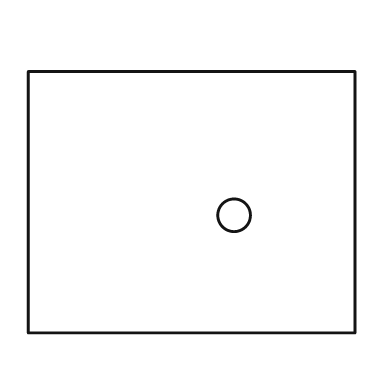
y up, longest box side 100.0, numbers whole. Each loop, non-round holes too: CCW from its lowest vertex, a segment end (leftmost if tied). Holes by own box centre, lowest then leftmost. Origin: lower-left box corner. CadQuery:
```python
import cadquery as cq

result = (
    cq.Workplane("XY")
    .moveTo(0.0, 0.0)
    .lineTo(100.0, 0.0)
    .lineTo(100.0, 80.0)
    .lineTo(0.0, 80.0)
    .close()
    .moveTo(63.0, 36.0)
    .circle(5.0)
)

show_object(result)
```